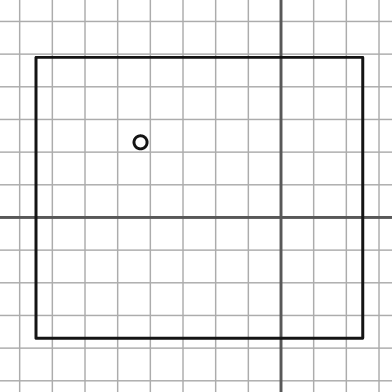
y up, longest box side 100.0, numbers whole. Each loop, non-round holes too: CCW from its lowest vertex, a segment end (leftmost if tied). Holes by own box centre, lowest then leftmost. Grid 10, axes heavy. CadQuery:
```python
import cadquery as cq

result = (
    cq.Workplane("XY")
    .moveTo(-75.0, -37.0)
    .lineTo(25.0, -37.0)
    .lineTo(25.0, 49.0)
    .lineTo(-75.0, 49.0)
    .close()
    .moveTo(-43.0, 23.0)
    .circle(2.0)
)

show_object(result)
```